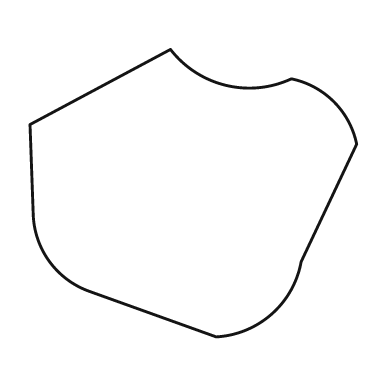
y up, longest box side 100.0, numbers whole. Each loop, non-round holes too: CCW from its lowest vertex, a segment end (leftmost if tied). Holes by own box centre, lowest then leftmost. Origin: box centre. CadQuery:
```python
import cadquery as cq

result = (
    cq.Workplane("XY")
    .moveTo(7.0, -44.0)
    .threePointArc((24.0, -37.0), (33.0, -21.0))
    .lineTo(50.0, 15.0)
    .threePointArc((43.0, 28.0), (30.0, 35.0))
    .threePointArc((10.0, 33.0), (-7.0, 44.0))
    .lineTo(-50.0, 21.0)
    .lineTo(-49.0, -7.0)
    .threePointArc((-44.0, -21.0), (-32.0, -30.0))
    .close()
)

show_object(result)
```